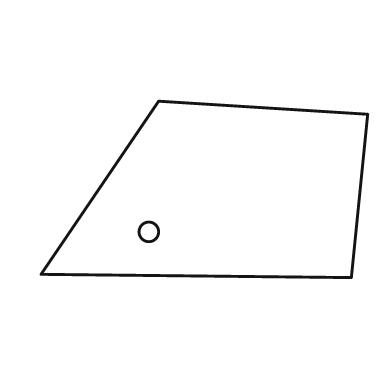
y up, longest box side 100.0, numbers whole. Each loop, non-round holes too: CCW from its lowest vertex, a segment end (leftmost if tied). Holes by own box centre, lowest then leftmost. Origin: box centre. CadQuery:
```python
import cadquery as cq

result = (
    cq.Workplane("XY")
    .moveTo(45.0, -27.0)
    .lineTo(50.0, 23.0)
    .lineTo(-14.0, 27.0)
    .lineTo(-50.0, -26.0)
    .close()
    .moveTo(-17.0, -13.0)
    .circle(3.0)
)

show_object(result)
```